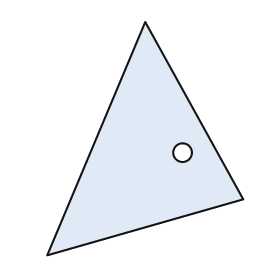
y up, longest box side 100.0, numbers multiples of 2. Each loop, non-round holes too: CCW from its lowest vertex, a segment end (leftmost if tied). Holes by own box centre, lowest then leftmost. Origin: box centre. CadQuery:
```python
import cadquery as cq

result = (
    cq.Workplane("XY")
    .moveTo(-42.0, -50.0)
    .lineTo(42.0, -26.0)
    .lineTo(0.0, 50.0)
    .close()
    .moveTo(16.0, -6.0)
    .circle(4.0)
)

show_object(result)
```